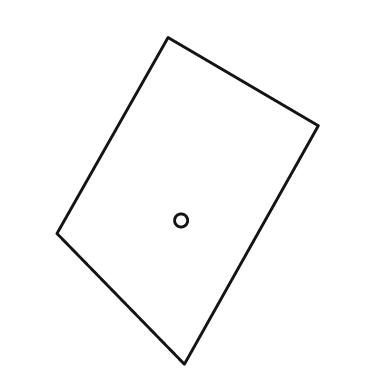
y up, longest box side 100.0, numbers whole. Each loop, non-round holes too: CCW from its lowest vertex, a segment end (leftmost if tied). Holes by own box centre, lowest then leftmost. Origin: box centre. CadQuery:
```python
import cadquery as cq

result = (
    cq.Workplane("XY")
    .moveTo(-1.0, -50.0)
    .lineTo(40.0, 23.0)
    .lineTo(-6.0, 50.0)
    .lineTo(-40.0, -10.0)
    .close()
    .moveTo(-2.0, -6.0)
    .circle(2.0)
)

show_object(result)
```